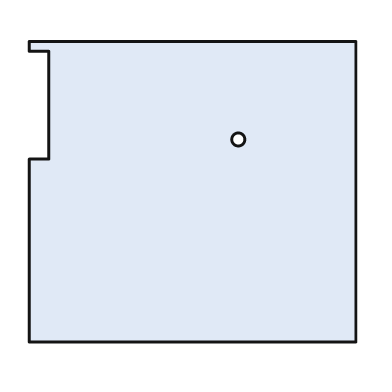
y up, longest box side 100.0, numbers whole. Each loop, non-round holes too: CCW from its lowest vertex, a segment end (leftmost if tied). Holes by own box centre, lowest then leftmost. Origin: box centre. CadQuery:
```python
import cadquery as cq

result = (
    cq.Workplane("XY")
    .moveTo(-50.0, -46.0)
    .lineTo(50.0, -46.0)
    .lineTo(50.0, 46.0)
    .lineTo(-50.0, 46.0)
    .lineTo(-50.0, 43.0)
    .lineTo(-44.0, 43.0)
    .lineTo(-44.0, 10.0)
    .lineTo(-50.0, 10.0)
    .close()
    .moveTo(14.0, 16.0)
    .circle(2.0)
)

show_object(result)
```